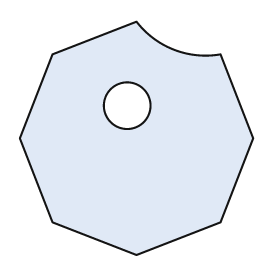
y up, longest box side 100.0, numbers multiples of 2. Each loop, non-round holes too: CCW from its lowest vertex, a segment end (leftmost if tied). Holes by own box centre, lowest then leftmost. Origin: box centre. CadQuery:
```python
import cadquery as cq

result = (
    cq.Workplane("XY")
    .moveTo(0.0, -50.0)
    .lineTo(36.0, -36.0)
    .lineTo(50.0, 0.0)
    .lineTo(36.0, 36.0)
    .threePointArc((16.0, 38.0), (0.0, 50.0))
    .lineTo(-36.0, 36.0)
    .lineTo(-50.0, 0.0)
    .lineTo(-36.0, -36.0)
    .close()
    .moveTo(-4.0, 14.0)
    .circle(10.0)
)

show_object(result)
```